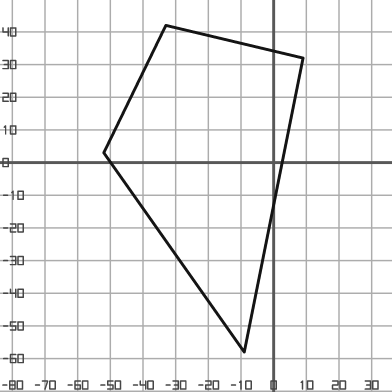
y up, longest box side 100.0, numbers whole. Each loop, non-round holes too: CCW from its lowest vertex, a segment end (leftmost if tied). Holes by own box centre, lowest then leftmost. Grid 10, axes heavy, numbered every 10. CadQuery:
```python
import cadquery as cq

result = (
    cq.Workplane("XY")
    .moveTo(-9.0, -58.0)
    .lineTo(9.0, 32.0)
    .lineTo(-33.0, 42.0)
    .lineTo(-52.0, 3.0)
    .close()
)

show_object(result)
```